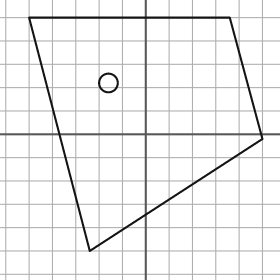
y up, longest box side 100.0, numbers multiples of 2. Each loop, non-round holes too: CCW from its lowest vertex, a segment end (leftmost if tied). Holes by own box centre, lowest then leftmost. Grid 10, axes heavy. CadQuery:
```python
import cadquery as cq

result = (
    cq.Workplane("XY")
    .moveTo(-24.0, -50.0)
    .lineTo(50.0, -2.0)
    .lineTo(36.0, 50.0)
    .lineTo(-50.0, 50.0)
    .close()
    .moveTo(-16.0, 22.0)
    .circle(4.0)
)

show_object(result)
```